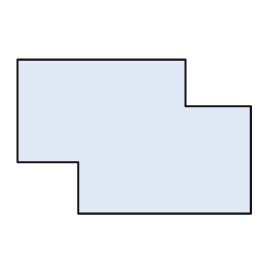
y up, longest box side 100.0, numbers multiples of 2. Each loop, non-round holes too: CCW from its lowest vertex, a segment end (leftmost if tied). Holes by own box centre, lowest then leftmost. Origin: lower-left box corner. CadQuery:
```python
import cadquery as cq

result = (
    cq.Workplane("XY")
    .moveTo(26.0, 0.0)
    .lineTo(100.0, 0.0)
    .lineTo(100.0, 46.0)
    .lineTo(72.0, 46.0)
    .lineTo(72.0, 66.0)
    .lineTo(0.0, 66.0)
    .lineTo(0.0, 22.0)
    .lineTo(26.0, 22.0)
    .close()
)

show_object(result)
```